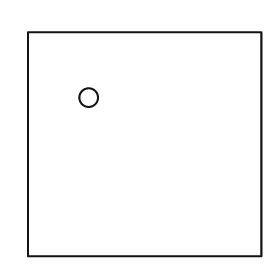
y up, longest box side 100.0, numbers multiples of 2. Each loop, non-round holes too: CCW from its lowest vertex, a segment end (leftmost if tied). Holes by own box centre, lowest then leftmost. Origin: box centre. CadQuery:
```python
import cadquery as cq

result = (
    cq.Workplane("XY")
    .moveTo(-50.0, -48.0)
    .lineTo(50.0, -48.0)
    .lineTo(50.0, 48.0)
    .lineTo(-50.0, 48.0)
    .close()
    .moveTo(-24.0, 20.0)
    .circle(4.0)
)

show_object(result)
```